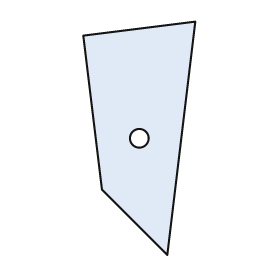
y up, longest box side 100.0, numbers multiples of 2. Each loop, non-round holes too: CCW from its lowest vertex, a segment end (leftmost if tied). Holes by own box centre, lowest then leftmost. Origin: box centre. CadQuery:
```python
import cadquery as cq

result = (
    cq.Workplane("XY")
    .moveTo(12.0, -50.0)
    .lineTo(24.0, 50.0)
    .lineTo(-24.0, 44.0)
    .lineTo(-16.0, -22.0)
    .close()
    .moveTo(0.0, 0.0)
    .circle(4.0)
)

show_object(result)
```